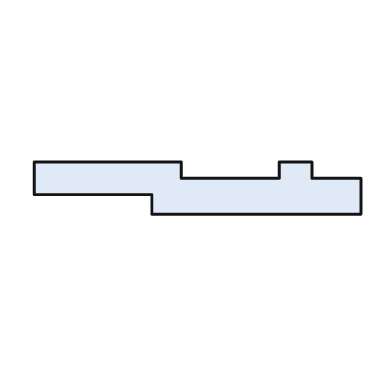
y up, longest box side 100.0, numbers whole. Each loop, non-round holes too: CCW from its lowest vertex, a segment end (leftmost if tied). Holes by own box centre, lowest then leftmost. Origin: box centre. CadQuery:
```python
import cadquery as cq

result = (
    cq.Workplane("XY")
    .moveTo(-14.0, -8.0)
    .lineTo(50.0, -8.0)
    .lineTo(50.0, 3.0)
    .lineTo(35.0, 3.0)
    .lineTo(35.0, 8.0)
    .lineTo(25.0, 8.0)
    .lineTo(25.0, 3.0)
    .lineTo(-5.0, 3.0)
    .lineTo(-5.0, 8.0)
    .lineTo(-50.0, 8.0)
    .lineTo(-50.0, -2.0)
    .lineTo(-14.0, -2.0)
    .close()
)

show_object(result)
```